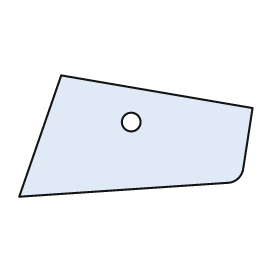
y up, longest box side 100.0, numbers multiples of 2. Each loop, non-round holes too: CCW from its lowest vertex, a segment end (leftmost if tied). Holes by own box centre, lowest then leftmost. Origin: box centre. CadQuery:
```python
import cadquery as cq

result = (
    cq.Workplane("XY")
    .moveTo(-50.0, -26.0)
    .lineTo(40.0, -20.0)
    .threePointArc((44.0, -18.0), (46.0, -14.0))
    .lineTo(50.0, 12.0)
    .lineTo(-32.0, 26.0)
    .close()
    .moveTo(-2.0, 6.0)
    .circle(4.0)
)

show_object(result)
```